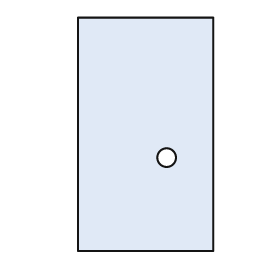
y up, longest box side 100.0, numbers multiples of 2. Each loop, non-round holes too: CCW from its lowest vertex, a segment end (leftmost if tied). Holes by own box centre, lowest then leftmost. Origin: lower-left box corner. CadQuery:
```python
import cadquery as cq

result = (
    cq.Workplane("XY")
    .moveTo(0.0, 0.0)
    .lineTo(58.0, 0.0)
    .lineTo(58.0, 100.0)
    .lineTo(0.0, 100.0)
    .close()
    .moveTo(38.0, 40.0)
    .circle(4.0)
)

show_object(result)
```